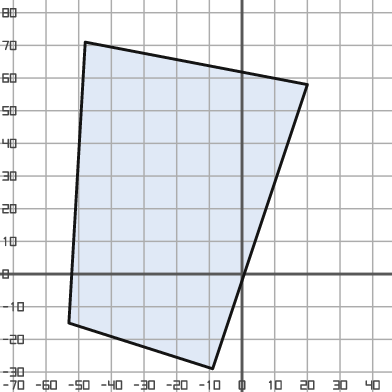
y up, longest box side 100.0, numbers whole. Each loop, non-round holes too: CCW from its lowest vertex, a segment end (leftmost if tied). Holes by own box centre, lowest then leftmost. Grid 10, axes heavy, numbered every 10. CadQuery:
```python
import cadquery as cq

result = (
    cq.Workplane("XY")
    .moveTo(-9.0, -29.0)
    .lineTo(20.0, 58.0)
    .lineTo(-48.0, 71.0)
    .lineTo(-53.0, -15.0)
    .close()
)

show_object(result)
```